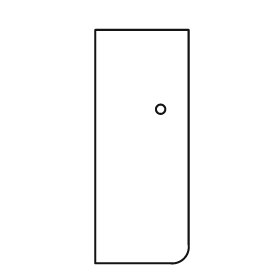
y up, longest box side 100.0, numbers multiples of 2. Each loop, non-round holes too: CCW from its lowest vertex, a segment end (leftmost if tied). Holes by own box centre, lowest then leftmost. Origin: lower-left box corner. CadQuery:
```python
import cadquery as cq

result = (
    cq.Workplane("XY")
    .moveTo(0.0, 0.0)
    .lineTo(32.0, 0.0)
    .threePointArc((38.0, 2.0), (40.0, 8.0))
    .lineTo(40.0, 100.0)
    .lineTo(0.0, 100.0)
    .close()
    .moveTo(28.0, 66.0)
    .circle(2.0)
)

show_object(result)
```